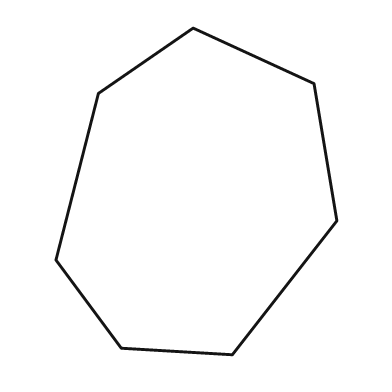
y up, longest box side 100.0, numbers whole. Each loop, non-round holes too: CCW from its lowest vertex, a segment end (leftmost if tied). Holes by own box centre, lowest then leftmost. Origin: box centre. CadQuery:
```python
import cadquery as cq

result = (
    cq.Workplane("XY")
    .moveTo(11.0, -50.0)
    .lineTo(43.0, -9.0)
    .lineTo(36.0, 33.0)
    .lineTo(-1.0, 50.0)
    .lineTo(-30.0, 30.0)
    .lineTo(-43.0, -21.0)
    .lineTo(-23.0, -48.0)
    .close()
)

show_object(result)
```